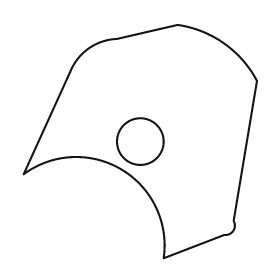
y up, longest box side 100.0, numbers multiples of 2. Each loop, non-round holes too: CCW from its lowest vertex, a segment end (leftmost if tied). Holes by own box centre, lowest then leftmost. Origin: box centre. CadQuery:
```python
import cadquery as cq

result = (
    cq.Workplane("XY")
    .moveTo(10.0, -50.0)
    .lineTo(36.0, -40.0)
    .threePointArc((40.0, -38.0), (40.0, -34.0))
    .lineTo(50.0, 26.0)
    .threePointArc((36.0, 42.0), (16.0, 50.0))
    .lineTo(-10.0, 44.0)
    .threePointArc((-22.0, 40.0), (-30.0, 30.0))
    .lineTo(-50.0, -14.0)
    .threePointArc((-8.0, -12.0), (10.0, -50.0))
    .close()
    .moveTo(0.0, 0.0)
    .circle(10.0)
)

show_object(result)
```